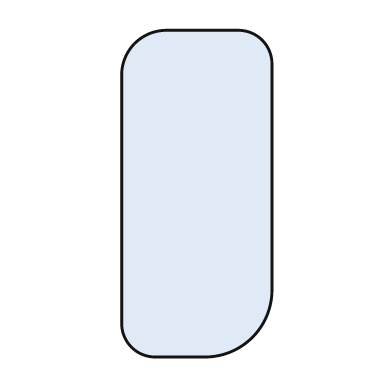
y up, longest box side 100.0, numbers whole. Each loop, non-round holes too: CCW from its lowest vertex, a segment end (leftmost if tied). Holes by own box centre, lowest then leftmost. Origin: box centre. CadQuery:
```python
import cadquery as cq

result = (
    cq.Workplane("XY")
    .moveTo(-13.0, -50.0)
    .lineTo(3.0, -50.0)
    .threePointArc((17.0, -44.0), (23.0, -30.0))
    .lineTo(23.0, 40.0)
    .threePointArc((20.0, 47.0), (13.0, 50.0))
    .lineTo(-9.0, 50.0)
    .threePointArc((-19.0, 46.0), (-23.0, 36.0))
    .lineTo(-23.0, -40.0)
    .threePointArc((-20.0, -47.0), (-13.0, -50.0))
    .close()
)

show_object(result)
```